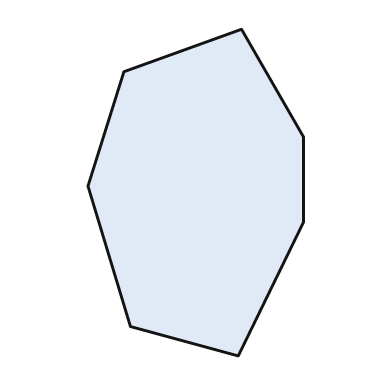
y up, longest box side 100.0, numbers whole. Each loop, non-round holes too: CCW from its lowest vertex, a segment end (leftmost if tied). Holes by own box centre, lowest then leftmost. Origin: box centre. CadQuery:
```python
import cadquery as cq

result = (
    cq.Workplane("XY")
    .moveTo(13.0, -50.0)
    .lineTo(33.0, -9.0)
    .lineTo(33.0, 17.0)
    .lineTo(14.0, 50.0)
    .lineTo(-22.0, 37.0)
    .lineTo(-33.0, 2.0)
    .lineTo(-20.0, -41.0)
    .close()
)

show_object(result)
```